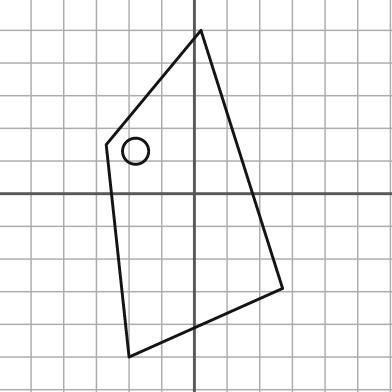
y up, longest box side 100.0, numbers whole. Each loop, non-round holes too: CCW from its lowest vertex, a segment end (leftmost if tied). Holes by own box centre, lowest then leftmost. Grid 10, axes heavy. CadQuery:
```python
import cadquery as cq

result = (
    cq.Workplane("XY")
    .moveTo(-20.0, -50.0)
    .lineTo(27.0, -29.0)
    .lineTo(2.0, 50.0)
    .lineTo(-27.0, 15.0)
    .close()
    .moveTo(-18.0, 13.0)
    .circle(4.0)
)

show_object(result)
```